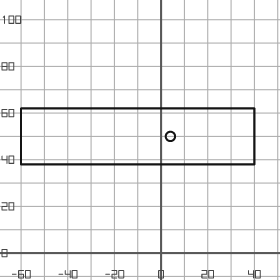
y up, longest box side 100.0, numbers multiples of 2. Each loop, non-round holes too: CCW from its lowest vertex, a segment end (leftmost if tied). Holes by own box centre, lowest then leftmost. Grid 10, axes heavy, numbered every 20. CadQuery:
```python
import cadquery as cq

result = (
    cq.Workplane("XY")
    .moveTo(-60.0, 38.0)
    .lineTo(40.0, 38.0)
    .lineTo(40.0, 62.0)
    .lineTo(-60.0, 62.0)
    .close()
    .moveTo(4.0, 50.0)
    .circle(2.0)
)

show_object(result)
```